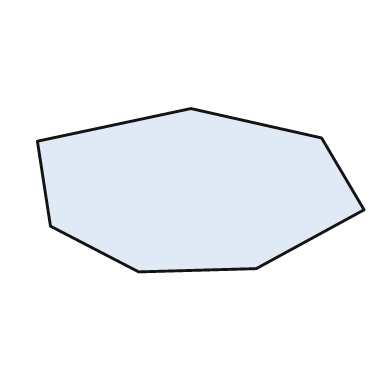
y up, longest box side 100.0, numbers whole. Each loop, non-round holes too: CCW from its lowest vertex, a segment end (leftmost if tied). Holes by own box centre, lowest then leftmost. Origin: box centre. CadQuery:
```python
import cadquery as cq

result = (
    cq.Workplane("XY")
    .moveTo(-19.0, -25.0)
    .lineTo(17.0, -24.0)
    .lineTo(50.0, -6.0)
    .lineTo(37.0, 16.0)
    .lineTo(-3.0, 25.0)
    .lineTo(-50.0, 15.0)
    .lineTo(-46.0, -11.0)
    .close()
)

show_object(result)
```